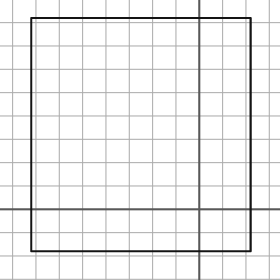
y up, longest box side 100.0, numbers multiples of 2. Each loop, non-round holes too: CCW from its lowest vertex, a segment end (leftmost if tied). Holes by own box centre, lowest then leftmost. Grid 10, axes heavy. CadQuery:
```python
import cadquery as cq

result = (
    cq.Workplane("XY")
    .moveTo(-72.0, -18.0)
    .lineTo(22.0, -18.0)
    .lineTo(22.0, 82.0)
    .lineTo(-72.0, 82.0)
    .close()
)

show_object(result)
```